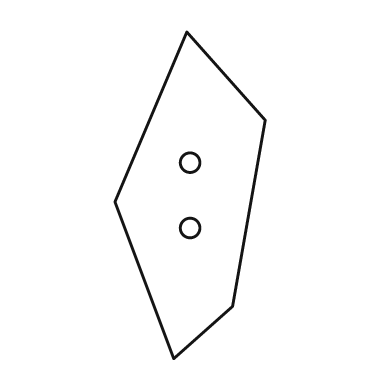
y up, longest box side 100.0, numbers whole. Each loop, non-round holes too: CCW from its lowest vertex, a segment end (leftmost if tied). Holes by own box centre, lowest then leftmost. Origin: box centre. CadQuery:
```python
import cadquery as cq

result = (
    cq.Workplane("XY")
    .moveTo(-5.0, -50.0)
    .lineTo(13.0, -34.0)
    .lineTo(23.0, 23.0)
    .lineTo(-1.0, 50.0)
    .lineTo(-23.0, -2.0)
    .close()
    .moveTo(0.0, -10.0)
    .circle(3.0)
    .moveTo(0.0, 10.0)
    .circle(3.0)
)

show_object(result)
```